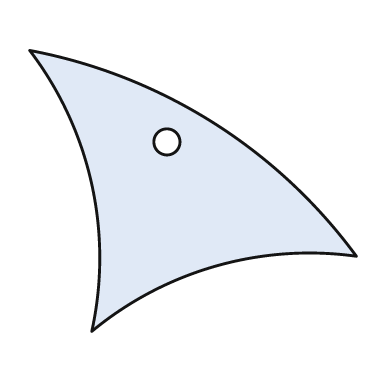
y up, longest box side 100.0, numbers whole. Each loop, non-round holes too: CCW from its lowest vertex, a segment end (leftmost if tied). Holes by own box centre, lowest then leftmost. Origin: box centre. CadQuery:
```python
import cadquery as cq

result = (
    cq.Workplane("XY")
    .moveTo(-31.0, -43.0)
    .threePointArc((7.0, -23.0), (50.0, -20.0))
    .threePointArc((6.0, 21.0), (-50.0, 43.0))
    .threePointArc((-31.0, 2.0), (-31.0, -43.0))
    .close()
    .moveTo(-8.0, 15.0)
    .circle(4.0)
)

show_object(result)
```